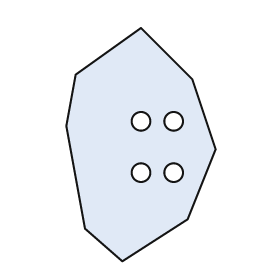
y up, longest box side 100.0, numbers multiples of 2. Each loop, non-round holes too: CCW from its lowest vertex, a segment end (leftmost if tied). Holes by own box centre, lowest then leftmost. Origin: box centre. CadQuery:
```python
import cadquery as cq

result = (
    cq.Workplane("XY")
    .moveTo(-8.0, -50.0)
    .lineTo(20.0, -32.0)
    .lineTo(32.0, -2.0)
    .lineTo(22.0, 28.0)
    .lineTo(0.0, 50.0)
    .lineTo(-28.0, 30.0)
    .lineTo(-32.0, 8.0)
    .lineTo(-24.0, -36.0)
    .close()
    .moveTo(0.0, -12.0)
    .circle(4.0)
    .moveTo(14.0, -12.0)
    .circle(4.0)
    .moveTo(0.0, 10.0)
    .circle(4.0)
    .moveTo(14.0, 10.0)
    .circle(4.0)
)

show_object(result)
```